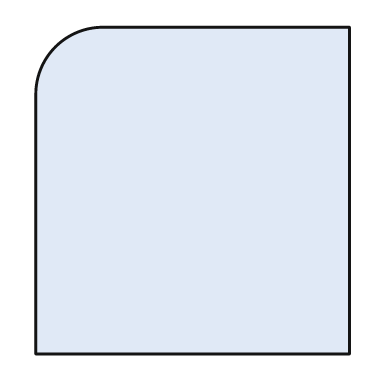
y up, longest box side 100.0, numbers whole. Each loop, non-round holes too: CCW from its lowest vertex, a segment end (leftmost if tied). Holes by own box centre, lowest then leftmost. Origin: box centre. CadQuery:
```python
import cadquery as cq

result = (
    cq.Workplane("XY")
    .moveTo(-48.0, -50.0)
    .lineTo(48.0, -50.0)
    .lineTo(48.0, 50.0)
    .lineTo(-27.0, 50.0)
    .threePointArc((-42.0, 44.0), (-48.0, 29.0))
    .close()
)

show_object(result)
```